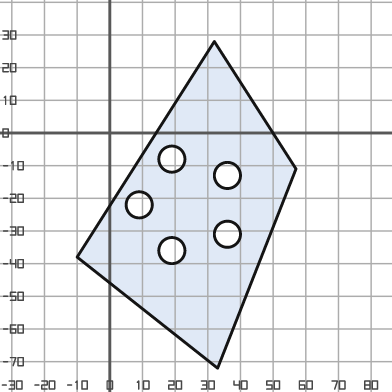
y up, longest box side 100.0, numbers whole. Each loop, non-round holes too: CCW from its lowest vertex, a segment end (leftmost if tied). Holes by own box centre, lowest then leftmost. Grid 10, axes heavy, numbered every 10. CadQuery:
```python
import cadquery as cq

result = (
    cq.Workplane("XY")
    .moveTo(33.0, -72.0)
    .lineTo(57.0, -11.0)
    .lineTo(32.0, 28.0)
    .lineTo(-10.0, -38.0)
    .close()
    .moveTo(19.0, -36.0)
    .circle(4.0)
    .moveTo(36.0, -31.0)
    .circle(4.0)
    .moveTo(9.0, -22.0)
    .circle(4.0)
    .moveTo(36.0, -13.0)
    .circle(4.0)
    .moveTo(19.0, -8.0)
    .circle(4.0)
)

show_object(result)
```